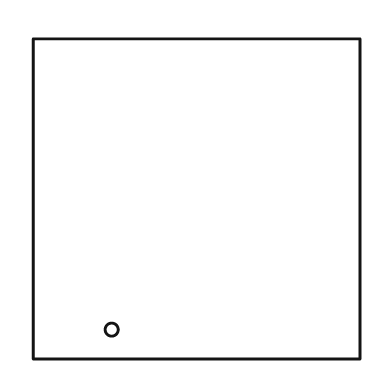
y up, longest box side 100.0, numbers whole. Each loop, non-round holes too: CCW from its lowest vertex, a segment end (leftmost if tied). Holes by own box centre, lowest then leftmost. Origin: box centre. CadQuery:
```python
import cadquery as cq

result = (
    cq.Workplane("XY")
    .moveTo(-50.0, -49.0)
    .lineTo(50.0, -49.0)
    .lineTo(50.0, 49.0)
    .lineTo(-50.0, 49.0)
    .close()
    .moveTo(-26.0, -40.0)
    .circle(2.0)
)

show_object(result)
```